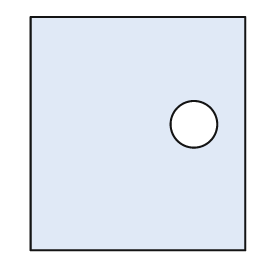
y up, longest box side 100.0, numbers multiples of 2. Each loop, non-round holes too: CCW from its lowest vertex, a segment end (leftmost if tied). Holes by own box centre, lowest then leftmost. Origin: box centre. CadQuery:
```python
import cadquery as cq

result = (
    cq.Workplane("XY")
    .moveTo(-46.0, -50.0)
    .lineTo(46.0, -50.0)
    .lineTo(46.0, 50.0)
    .lineTo(-46.0, 50.0)
    .close()
    .moveTo(24.0, 4.0)
    .circle(10.0)
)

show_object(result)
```